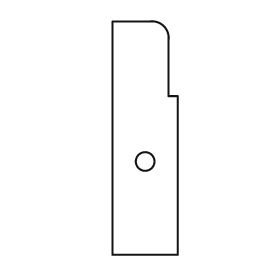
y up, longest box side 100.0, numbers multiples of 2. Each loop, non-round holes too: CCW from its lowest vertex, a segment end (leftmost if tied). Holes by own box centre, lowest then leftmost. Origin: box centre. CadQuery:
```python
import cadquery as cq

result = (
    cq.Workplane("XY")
    .moveTo(-14.0, -50.0)
    .lineTo(14.0, -50.0)
    .lineTo(14.0, 18.0)
    .lineTo(10.0, 18.0)
    .lineTo(10.0, 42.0)
    .threePointArc((8.0, 48.0), (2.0, 50.0))
    .lineTo(-14.0, 50.0)
    .close()
    .moveTo(0.0, -10.0)
    .circle(4.0)
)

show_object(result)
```